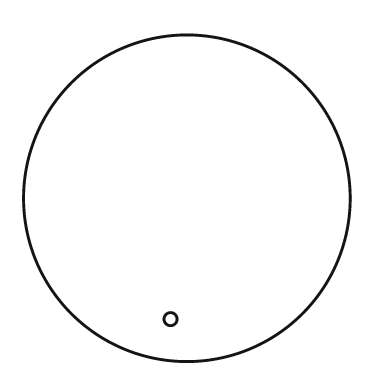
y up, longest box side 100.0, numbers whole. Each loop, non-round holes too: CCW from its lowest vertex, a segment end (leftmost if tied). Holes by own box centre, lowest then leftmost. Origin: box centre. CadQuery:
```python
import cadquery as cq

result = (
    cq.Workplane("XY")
    .moveTo(0.0, 0.0)
    .circle(50.0)
    .moveTo(-5.0, -37.0)
    .circle(2.0)
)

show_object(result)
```